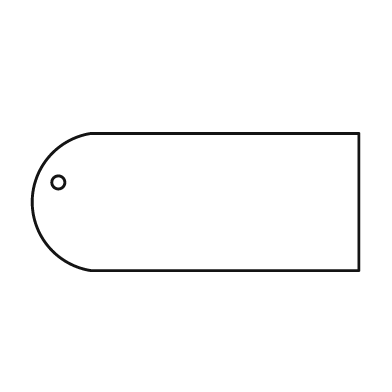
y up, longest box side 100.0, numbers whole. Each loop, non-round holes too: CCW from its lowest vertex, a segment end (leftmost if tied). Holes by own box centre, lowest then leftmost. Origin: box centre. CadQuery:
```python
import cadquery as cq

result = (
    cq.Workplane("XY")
    .moveTo(-32.0, -21.0)
    .lineTo(50.0, -21.0)
    .lineTo(50.0, 21.0)
    .lineTo(-32.0, 21.0)
    .threePointArc((-50.0, 0.0), (-32.0, -21.0))
    .close()
    .moveTo(-42.0, 6.0)
    .circle(2.0)
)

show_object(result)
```